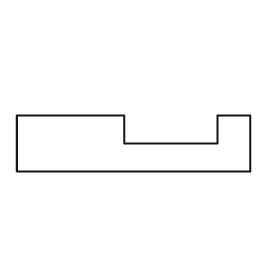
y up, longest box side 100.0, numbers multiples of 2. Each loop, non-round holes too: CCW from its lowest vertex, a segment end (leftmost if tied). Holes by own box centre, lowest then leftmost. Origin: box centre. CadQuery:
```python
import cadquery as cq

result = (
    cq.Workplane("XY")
    .moveTo(-50.0, -12.0)
    .lineTo(50.0, -12.0)
    .lineTo(50.0, 12.0)
    .lineTo(36.0, 12.0)
    .lineTo(36.0, 0.0)
    .lineTo(-4.0, 0.0)
    .lineTo(-4.0, 12.0)
    .lineTo(-50.0, 12.0)
    .close()
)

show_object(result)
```